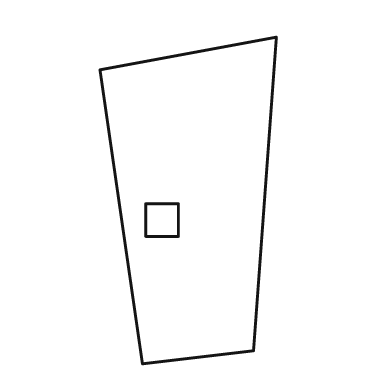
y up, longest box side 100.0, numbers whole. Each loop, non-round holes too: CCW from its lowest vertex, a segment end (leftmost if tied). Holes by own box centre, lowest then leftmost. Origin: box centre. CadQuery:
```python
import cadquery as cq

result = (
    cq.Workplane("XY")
    .moveTo(-14.0, -50.0)
    .lineTo(20.0, -46.0)
    .lineTo(27.0, 50.0)
    .lineTo(-27.0, 40.0)
    .close()
    .moveTo(-13.0, -11.0)
    .lineTo(-3.0, -11.0)
    .lineTo(-3.0, -1.0)
    .lineTo(-13.0, -1.0)
    .close()
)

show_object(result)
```